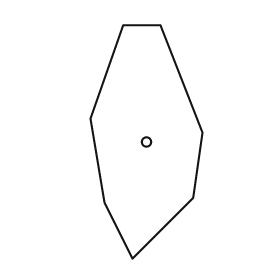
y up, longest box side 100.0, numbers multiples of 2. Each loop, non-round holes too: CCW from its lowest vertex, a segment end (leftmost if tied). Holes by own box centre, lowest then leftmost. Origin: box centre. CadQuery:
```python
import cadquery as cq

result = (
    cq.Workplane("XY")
    .moveTo(-6.0, -50.0)
    .lineTo(20.0, -24.0)
    .lineTo(24.0, 4.0)
    .lineTo(6.0, 50.0)
    .lineTo(-10.0, 50.0)
    .lineTo(-24.0, 10.0)
    .lineTo(-18.0, -26.0)
    .close()
    .moveTo(0.0, 0.0)
    .circle(2.0)
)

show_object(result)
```